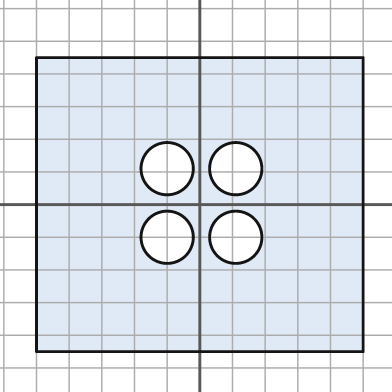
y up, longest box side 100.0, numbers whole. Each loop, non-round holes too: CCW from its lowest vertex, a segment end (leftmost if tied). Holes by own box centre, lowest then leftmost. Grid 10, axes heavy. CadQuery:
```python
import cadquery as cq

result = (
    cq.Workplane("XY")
    .moveTo(-50.0, -45.0)
    .lineTo(50.0, -45.0)
    .lineTo(50.0, 45.0)
    .lineTo(-50.0, 45.0)
    .close()
    .moveTo(-10.0, -10.0)
    .circle(8.0)
    .moveTo(11.0, -10.0)
    .circle(8.0)
    .moveTo(-10.0, 11.0)
    .circle(8.0)
    .moveTo(11.0, 11.0)
    .circle(8.0)
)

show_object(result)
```